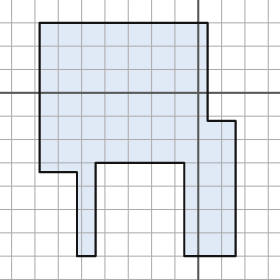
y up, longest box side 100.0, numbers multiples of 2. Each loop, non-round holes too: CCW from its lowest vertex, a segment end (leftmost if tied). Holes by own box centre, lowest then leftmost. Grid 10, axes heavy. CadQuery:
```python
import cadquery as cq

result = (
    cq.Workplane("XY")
    .moveTo(-52.0, -70.0)
    .lineTo(-44.0, -70.0)
    .lineTo(-44.0, -30.0)
    .lineTo(-6.0, -30.0)
    .lineTo(-6.0, -70.0)
    .lineTo(16.0, -70.0)
    .lineTo(16.0, -12.0)
    .lineTo(4.0, -12.0)
    .lineTo(4.0, 30.0)
    .lineTo(-68.0, 30.0)
    .lineTo(-68.0, -34.0)
    .lineTo(-52.0, -34.0)
    .close()
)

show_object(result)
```